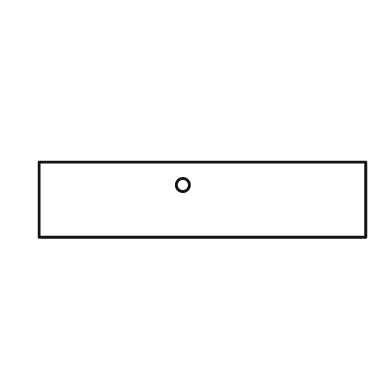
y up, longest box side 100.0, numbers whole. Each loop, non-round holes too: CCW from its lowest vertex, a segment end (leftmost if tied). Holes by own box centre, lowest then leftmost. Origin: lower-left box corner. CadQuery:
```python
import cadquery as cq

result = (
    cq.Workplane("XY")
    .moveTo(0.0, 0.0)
    .lineTo(100.0, 0.0)
    .lineTo(100.0, 23.0)
    .lineTo(0.0, 23.0)
    .close()
    .moveTo(44.0, 16.0)
    .circle(2.0)
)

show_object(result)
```